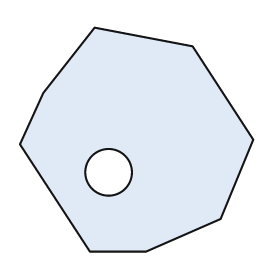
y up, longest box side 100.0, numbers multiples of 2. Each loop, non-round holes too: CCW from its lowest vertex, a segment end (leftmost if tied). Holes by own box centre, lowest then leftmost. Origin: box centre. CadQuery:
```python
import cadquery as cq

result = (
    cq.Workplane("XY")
    .moveTo(-20.0, -48.0)
    .lineTo(4.0, -48.0)
    .lineTo(36.0, -34.0)
    .lineTo(50.0, 0.0)
    .lineTo(24.0, 40.0)
    .lineTo(-18.0, 48.0)
    .lineTo(-40.0, 20.0)
    .lineTo(-50.0, -2.0)
    .close()
    .moveTo(-12.0, -14.0)
    .circle(10.0)
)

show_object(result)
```